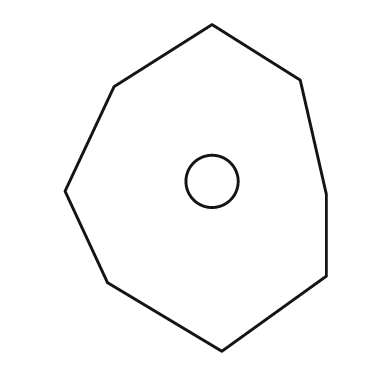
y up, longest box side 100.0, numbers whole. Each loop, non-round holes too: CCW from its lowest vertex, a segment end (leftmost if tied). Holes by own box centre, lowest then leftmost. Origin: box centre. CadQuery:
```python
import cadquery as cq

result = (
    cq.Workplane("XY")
    .moveTo(8.0, -50.0)
    .lineTo(40.0, -27.0)
    .lineTo(40.0, -2.0)
    .lineTo(32.0, 33.0)
    .lineTo(5.0, 50.0)
    .lineTo(-25.0, 31.0)
    .lineTo(-40.0, -1.0)
    .lineTo(-27.0, -29.0)
    .close()
    .moveTo(5.0, 2.0)
    .circle(8.0)
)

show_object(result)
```